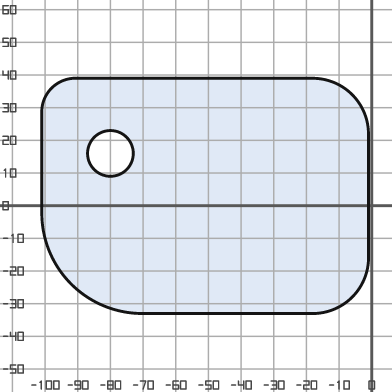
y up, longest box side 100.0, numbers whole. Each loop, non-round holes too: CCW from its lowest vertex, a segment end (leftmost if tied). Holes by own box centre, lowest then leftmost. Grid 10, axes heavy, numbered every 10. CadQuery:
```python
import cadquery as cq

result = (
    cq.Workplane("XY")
    .moveTo(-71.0, -33.0)
    .lineTo(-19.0, -33.0)
    .threePointArc((-6.0, -28.0), (-1.0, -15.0))
    .lineTo(-1.0, 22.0)
    .threePointArc((-6.0, 34.0), (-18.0, 39.0))
    .lineTo(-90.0, 39.0)
    .threePointArc((-98.0, 36.0), (-101.0, 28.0))
    .lineTo(-101.0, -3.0)
    .threePointArc((-92.0, -24.0), (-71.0, -33.0))
    .close()
    .moveTo(-80.0, 16.0)
    .circle(7.0)
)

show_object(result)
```